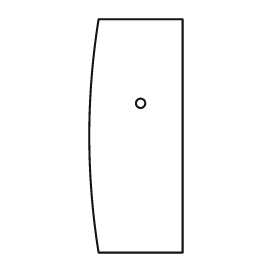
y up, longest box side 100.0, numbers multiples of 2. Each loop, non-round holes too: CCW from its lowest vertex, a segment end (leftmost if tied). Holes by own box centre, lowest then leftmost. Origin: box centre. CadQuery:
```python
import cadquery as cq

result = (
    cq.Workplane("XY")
    .moveTo(-16.0, -50.0)
    .lineTo(20.0, -50.0)
    .lineTo(20.0, 50.0)
    .lineTo(-16.0, 50.0)
    .threePointArc((-20.0, 0.0), (-16.0, -50.0))
    .close()
    .moveTo(2.0, 14.0)
    .circle(2.0)
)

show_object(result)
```